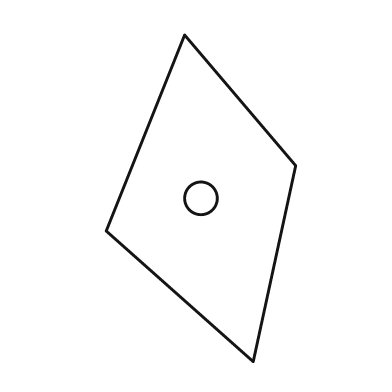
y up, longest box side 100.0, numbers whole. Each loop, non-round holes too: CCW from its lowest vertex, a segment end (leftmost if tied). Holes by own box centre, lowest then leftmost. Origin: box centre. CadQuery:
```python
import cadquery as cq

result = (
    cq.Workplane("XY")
    .moveTo(16.0, -50.0)
    .lineTo(29.0, 10.0)
    .lineTo(-5.0, 50.0)
    .lineTo(-29.0, -10.0)
    .close()
    .moveTo(0.0, 0.0)
    .circle(5.0)
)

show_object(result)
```